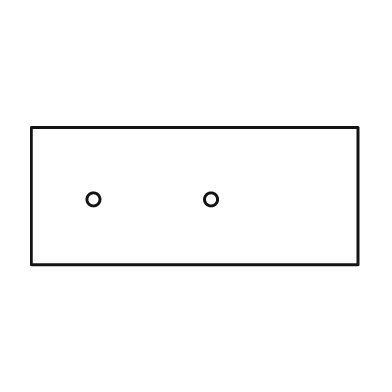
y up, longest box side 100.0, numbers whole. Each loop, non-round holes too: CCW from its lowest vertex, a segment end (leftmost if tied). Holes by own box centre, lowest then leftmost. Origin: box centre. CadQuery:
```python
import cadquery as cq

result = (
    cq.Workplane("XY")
    .moveTo(-50.0, -21.0)
    .lineTo(50.0, -21.0)
    .lineTo(50.0, 21.0)
    .lineTo(-50.0, 21.0)
    .close()
    .moveTo(-31.0, -1.0)
    .circle(2.0)
    .moveTo(5.0, -1.0)
    .circle(2.0)
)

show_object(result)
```